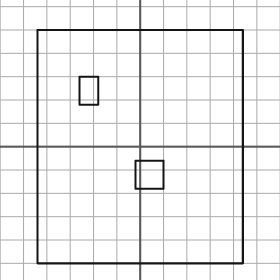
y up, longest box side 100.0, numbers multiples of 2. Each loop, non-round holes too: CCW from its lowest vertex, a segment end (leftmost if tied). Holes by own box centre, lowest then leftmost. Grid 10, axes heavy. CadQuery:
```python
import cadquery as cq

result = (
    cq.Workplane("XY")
    .moveTo(-44.0, -50.0)
    .lineTo(44.0, -50.0)
    .lineTo(44.0, 50.0)
    .lineTo(-44.0, 50.0)
    .close()
    .moveTo(-2.0, -18.0)
    .lineTo(10.0, -18.0)
    .lineTo(10.0, -6.0)
    .lineTo(-2.0, -6.0)
    .close()
    .moveTo(-26.0, 18.0)
    .lineTo(-18.0, 18.0)
    .lineTo(-18.0, 30.0)
    .lineTo(-26.0, 30.0)
    .close()
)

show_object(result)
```